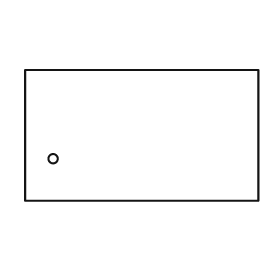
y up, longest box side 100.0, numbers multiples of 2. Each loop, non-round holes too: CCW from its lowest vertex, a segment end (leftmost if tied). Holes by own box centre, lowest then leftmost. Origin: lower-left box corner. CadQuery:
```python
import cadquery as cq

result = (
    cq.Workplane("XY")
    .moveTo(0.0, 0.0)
    .lineTo(100.0, 0.0)
    .lineTo(100.0, 56.0)
    .lineTo(0.0, 56.0)
    .close()
    .moveTo(12.0, 18.0)
    .circle(2.0)
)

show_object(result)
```